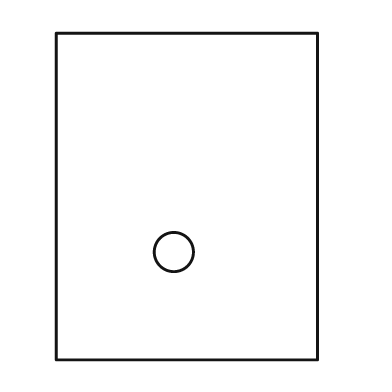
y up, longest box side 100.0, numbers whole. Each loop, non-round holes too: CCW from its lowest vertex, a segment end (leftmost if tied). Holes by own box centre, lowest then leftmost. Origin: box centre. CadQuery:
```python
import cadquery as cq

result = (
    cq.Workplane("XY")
    .moveTo(-40.0, -50.0)
    .lineTo(40.0, -50.0)
    .lineTo(40.0, 50.0)
    .lineTo(-40.0, 50.0)
    .close()
    .moveTo(-4.0, -17.0)
    .circle(6.0)
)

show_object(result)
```